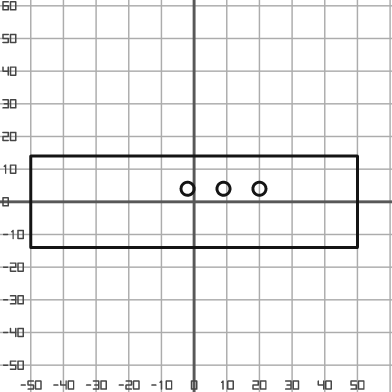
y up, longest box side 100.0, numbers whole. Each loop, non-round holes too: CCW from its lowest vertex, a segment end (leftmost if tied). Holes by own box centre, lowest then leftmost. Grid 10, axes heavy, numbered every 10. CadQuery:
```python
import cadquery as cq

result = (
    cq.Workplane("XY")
    .moveTo(-50.0, -14.0)
    .lineTo(50.0, -14.0)
    .lineTo(50.0, 14.0)
    .lineTo(-50.0, 14.0)
    .close()
    .moveTo(-2.0, 4.0)
    .circle(2.0)
    .moveTo(9.0, 4.0)
    .circle(2.0)
    .moveTo(20.0, 4.0)
    .circle(2.0)
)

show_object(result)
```